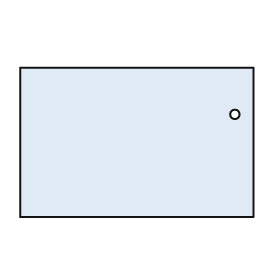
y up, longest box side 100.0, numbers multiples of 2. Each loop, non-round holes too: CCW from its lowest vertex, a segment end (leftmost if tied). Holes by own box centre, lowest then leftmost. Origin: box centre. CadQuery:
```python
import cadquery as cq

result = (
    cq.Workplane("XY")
    .moveTo(-50.0, -32.0)
    .lineTo(50.0, -32.0)
    .lineTo(50.0, 32.0)
    .lineTo(-50.0, 32.0)
    .close()
    .moveTo(42.0, 12.0)
    .circle(2.0)
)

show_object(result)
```